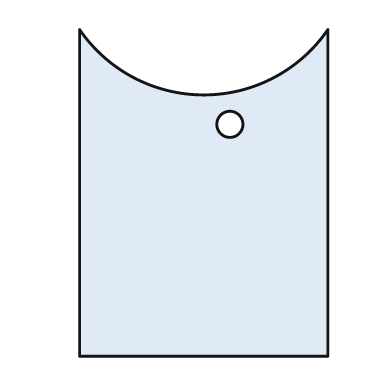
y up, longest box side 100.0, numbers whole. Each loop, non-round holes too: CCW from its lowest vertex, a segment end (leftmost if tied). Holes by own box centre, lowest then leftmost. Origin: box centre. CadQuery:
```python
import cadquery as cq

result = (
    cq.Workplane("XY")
    .moveTo(-38.0, -50.0)
    .lineTo(38.0, -50.0)
    .lineTo(38.0, 50.0)
    .threePointArc((0.0, 30.0), (-38.0, 50.0))
    .close()
    .moveTo(8.0, 21.0)
    .circle(4.0)
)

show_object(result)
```